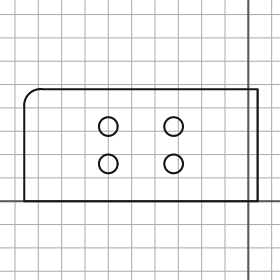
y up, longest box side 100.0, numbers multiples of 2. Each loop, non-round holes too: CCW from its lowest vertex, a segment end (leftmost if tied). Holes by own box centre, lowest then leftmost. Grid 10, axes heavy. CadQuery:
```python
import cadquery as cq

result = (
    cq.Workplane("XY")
    .moveTo(-96.0, 0.0)
    .lineTo(4.0, 0.0)
    .lineTo(4.0, 48.0)
    .lineTo(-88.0, 48.0)
    .threePointArc((-94.0, 46.0), (-96.0, 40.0))
    .close()
    .moveTo(-60.0, 16.0)
    .circle(4.0)
    .moveTo(-32.0, 16.0)
    .circle(4.0)
    .moveTo(-60.0, 32.0)
    .circle(4.0)
    .moveTo(-32.0, 32.0)
    .circle(4.0)
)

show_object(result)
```